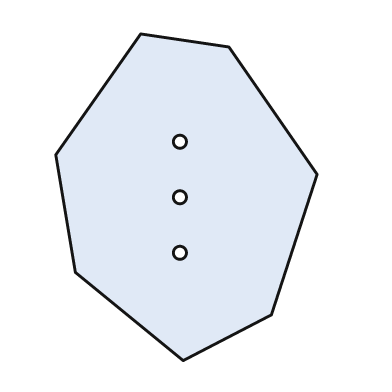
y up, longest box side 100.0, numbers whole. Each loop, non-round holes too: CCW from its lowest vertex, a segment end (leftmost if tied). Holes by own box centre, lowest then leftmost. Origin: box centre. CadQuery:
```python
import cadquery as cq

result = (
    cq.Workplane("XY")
    .moveTo(-1.0, -50.0)
    .lineTo(26.0, -36.0)
    .lineTo(40.0, 7.0)
    .lineTo(13.0, 46.0)
    .lineTo(-14.0, 50.0)
    .lineTo(-40.0, 13.0)
    .lineTo(-34.0, -23.0)
    .close()
    .moveTo(-2.0, -17.0)
    .circle(2.0)
    .moveTo(-2.0, 0.0)
    .circle(2.0)
    .moveTo(-2.0, 17.0)
    .circle(2.0)
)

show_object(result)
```